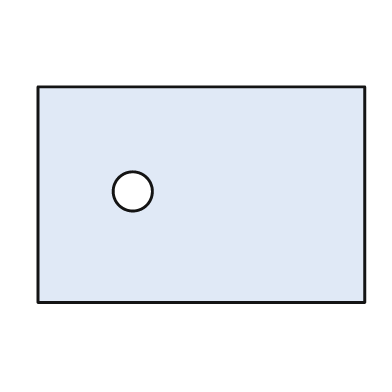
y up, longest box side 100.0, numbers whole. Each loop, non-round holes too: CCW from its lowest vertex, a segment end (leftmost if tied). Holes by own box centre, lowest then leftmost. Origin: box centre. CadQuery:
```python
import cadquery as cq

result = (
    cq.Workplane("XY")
    .moveTo(-50.0, -33.0)
    .lineTo(50.0, -33.0)
    .lineTo(50.0, 33.0)
    .lineTo(-50.0, 33.0)
    .close()
    .moveTo(-21.0, 1.0)
    .circle(6.0)
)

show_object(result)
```